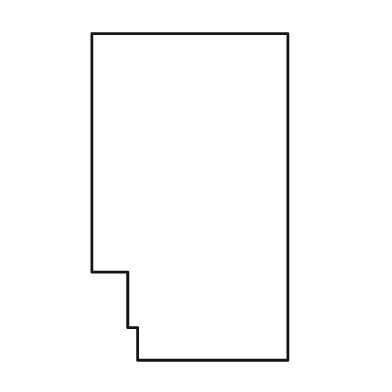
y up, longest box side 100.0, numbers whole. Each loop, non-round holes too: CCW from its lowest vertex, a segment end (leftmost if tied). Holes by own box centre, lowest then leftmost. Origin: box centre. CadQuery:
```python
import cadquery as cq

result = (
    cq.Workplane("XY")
    .moveTo(-16.0, -50.0)
    .lineTo(30.0, -50.0)
    .lineTo(30.0, 50.0)
    .lineTo(-30.0, 50.0)
    .lineTo(-30.0, -23.0)
    .lineTo(-19.0, -23.0)
    .lineTo(-19.0, -40.0)
    .lineTo(-16.0, -40.0)
    .close()
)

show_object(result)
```